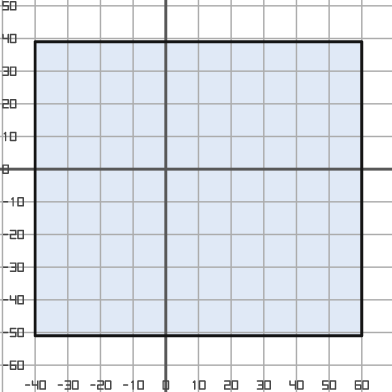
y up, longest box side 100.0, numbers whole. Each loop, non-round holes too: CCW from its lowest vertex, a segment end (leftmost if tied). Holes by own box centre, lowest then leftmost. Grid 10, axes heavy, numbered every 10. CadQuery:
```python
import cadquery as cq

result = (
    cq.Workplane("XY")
    .moveTo(-40.0, -51.0)
    .lineTo(60.0, -51.0)
    .lineTo(60.0, 39.0)
    .lineTo(-40.0, 39.0)
    .close()
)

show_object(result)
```